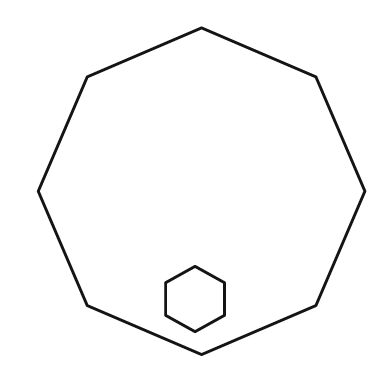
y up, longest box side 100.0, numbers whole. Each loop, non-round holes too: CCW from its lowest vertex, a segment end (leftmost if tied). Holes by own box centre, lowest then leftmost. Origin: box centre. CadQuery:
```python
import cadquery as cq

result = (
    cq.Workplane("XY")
    .moveTo(0.0, -50.0)
    .lineTo(35.0, -35.0)
    .lineTo(50.0, 0.0)
    .lineTo(35.0, 35.0)
    .lineTo(0.0, 50.0)
    .lineTo(-35.0, 35.0)
    .lineTo(-50.0, 0.0)
    .lineTo(-35.0, -35.0)
    .close()
    .moveTo(-2.0, -43.0)
    .lineTo(7.0, -38.0)
    .lineTo(7.0, -28.0)
    .lineTo(-2.0, -23.0)
    .lineTo(-11.0, -28.0)
    .lineTo(-11.0, -38.0)
    .close()
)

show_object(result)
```